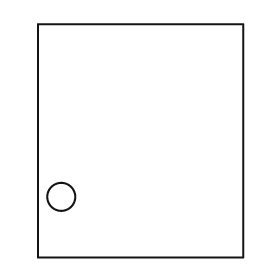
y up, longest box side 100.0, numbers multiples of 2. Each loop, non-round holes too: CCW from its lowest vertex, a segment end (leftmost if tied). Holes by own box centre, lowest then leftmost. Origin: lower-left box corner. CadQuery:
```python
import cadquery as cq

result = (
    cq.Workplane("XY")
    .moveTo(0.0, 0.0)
    .lineTo(88.0, 0.0)
    .lineTo(88.0, 100.0)
    .lineTo(0.0, 100.0)
    .close()
    .moveTo(10.0, 26.0)
    .circle(6.0)
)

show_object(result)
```